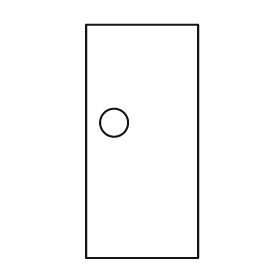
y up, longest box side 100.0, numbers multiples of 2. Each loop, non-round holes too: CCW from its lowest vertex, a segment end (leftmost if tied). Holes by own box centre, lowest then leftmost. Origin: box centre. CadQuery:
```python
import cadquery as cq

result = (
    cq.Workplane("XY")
    .moveTo(-24.0, -50.0)
    .lineTo(24.0, -50.0)
    .lineTo(24.0, 50.0)
    .lineTo(-24.0, 50.0)
    .close()
    .moveTo(-12.0, 8.0)
    .circle(6.0)
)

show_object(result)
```